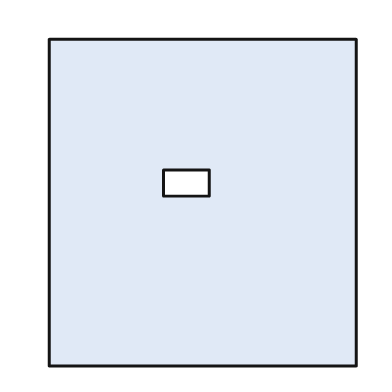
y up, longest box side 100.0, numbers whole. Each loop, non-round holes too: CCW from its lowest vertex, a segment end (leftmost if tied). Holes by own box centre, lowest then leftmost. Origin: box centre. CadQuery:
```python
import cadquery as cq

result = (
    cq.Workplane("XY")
    .moveTo(-47.0, -50.0)
    .lineTo(47.0, -50.0)
    .lineTo(47.0, 50.0)
    .lineTo(-47.0, 50.0)
    .close()
    .moveTo(-12.0, 2.0)
    .lineTo(2.0, 2.0)
    .lineTo(2.0, 10.0)
    .lineTo(-12.0, 10.0)
    .close()
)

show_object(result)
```